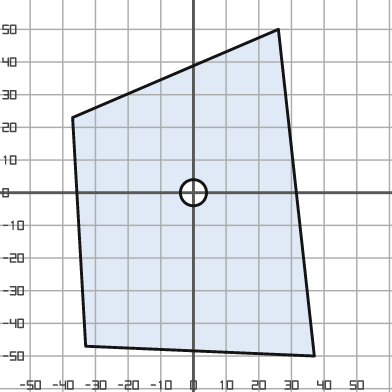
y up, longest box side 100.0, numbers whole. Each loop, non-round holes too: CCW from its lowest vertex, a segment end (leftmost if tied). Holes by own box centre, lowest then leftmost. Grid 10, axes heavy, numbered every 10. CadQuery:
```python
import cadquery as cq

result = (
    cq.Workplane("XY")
    .moveTo(37.0, -50.0)
    .lineTo(26.0, 50.0)
    .lineTo(-37.0, 23.0)
    .lineTo(-33.0, -47.0)
    .close()
    .moveTo(0.0, 0.0)
    .circle(4.0)
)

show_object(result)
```